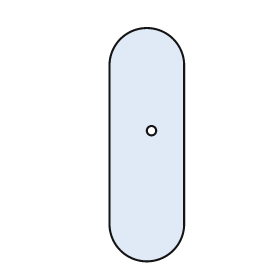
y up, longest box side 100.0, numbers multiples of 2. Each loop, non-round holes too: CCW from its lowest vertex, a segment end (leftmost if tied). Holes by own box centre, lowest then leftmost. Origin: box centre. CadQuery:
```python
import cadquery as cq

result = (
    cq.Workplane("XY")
    .moveTo(-16.0, -34.0)
    .threePointArc((0.0, -50.0), (16.0, -34.0))
    .lineTo(16.0, 34.0)
    .threePointArc((0.0, 50.0), (-16.0, 34.0))
    .close()
    .moveTo(2.0, 6.0)
    .circle(2.0)
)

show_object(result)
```